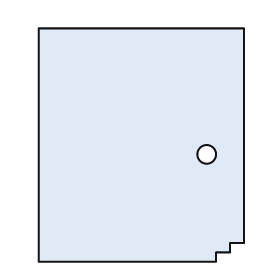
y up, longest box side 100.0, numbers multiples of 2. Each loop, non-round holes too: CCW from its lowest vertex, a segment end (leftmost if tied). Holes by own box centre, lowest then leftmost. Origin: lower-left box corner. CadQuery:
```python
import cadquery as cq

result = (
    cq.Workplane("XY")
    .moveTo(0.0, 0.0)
    .lineTo(76.0, 0.0)
    .lineTo(76.0, 4.0)
    .lineTo(82.0, 4.0)
    .lineTo(82.0, 8.0)
    .lineTo(88.0, 8.0)
    .lineTo(88.0, 100.0)
    .lineTo(0.0, 100.0)
    .close()
    .moveTo(72.0, 46.0)
    .circle(4.0)
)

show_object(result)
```